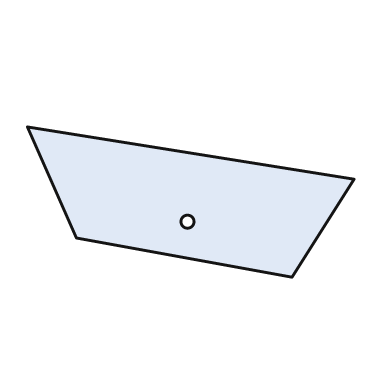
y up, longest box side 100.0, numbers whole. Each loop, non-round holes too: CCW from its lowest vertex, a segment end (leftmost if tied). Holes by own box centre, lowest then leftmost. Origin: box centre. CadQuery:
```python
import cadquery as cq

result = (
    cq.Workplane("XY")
    .moveTo(31.0, -23.0)
    .lineTo(50.0, 7.0)
    .lineTo(-50.0, 23.0)
    .lineTo(-35.0, -11.0)
    .close()
    .moveTo(-1.0, -6.0)
    .circle(2.0)
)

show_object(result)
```